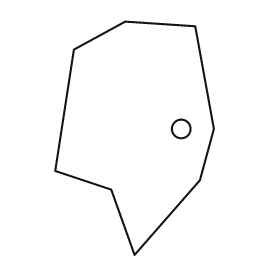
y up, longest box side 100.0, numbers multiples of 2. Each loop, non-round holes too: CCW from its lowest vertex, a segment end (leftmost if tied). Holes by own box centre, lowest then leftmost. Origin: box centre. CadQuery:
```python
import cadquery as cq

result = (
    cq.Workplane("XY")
    .moveTo(0.0, -50.0)
    .lineTo(28.0, -18.0)
    .lineTo(34.0, 4.0)
    .lineTo(26.0, 48.0)
    .lineTo(-4.0, 50.0)
    .lineTo(-26.0, 38.0)
    .lineTo(-34.0, -14.0)
    .lineTo(-10.0, -22.0)
    .close()
    .moveTo(20.0, 4.0)
    .circle(4.0)
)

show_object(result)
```